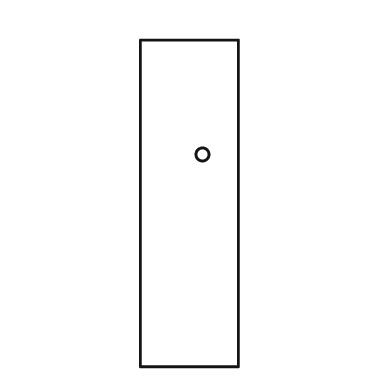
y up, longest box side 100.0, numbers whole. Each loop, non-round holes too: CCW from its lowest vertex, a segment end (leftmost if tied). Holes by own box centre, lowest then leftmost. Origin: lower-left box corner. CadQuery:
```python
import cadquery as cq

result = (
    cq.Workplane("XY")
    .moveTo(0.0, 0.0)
    .lineTo(30.0, 0.0)
    .lineTo(30.0, 100.0)
    .lineTo(0.0, 100.0)
    .close()
    .moveTo(19.0, 65.0)
    .circle(2.0)
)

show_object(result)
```